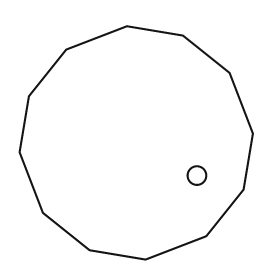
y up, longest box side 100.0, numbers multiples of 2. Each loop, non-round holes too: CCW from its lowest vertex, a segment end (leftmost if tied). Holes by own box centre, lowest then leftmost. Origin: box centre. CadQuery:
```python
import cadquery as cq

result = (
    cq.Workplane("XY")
    .moveTo(4.0, -50.0)
    .lineTo(30.0, -40.0)
    .lineTo(46.0, -20.0)
    .lineTo(50.0, 4.0)
    .lineTo(40.0, 30.0)
    .lineTo(20.0, 46.0)
    .lineTo(-4.0, 50.0)
    .lineTo(-30.0, 40.0)
    .lineTo(-46.0, 20.0)
    .lineTo(-50.0, -4.0)
    .lineTo(-40.0, -30.0)
    .lineTo(-20.0, -46.0)
    .close()
    .moveTo(26.0, -14.0)
    .circle(4.0)
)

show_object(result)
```